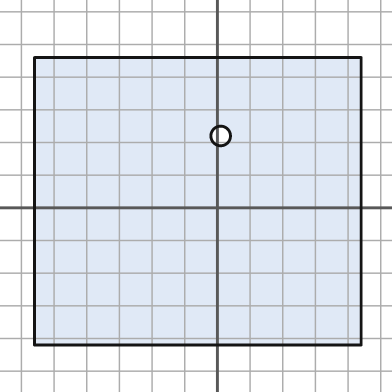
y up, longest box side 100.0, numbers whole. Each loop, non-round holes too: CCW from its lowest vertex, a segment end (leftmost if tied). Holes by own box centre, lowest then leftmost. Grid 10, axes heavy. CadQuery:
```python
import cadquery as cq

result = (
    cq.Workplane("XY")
    .moveTo(-56.0, -42.0)
    .lineTo(44.0, -42.0)
    .lineTo(44.0, 46.0)
    .lineTo(-56.0, 46.0)
    .close()
    .moveTo(1.0, 22.0)
    .circle(3.0)
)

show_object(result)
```